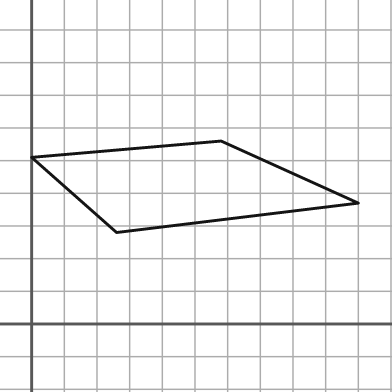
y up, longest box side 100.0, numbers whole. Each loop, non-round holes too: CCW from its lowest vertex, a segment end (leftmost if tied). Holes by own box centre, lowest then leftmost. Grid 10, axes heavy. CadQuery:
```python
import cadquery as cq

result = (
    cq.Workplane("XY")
    .moveTo(26.0, 28.0)
    .lineTo(100.0, 37.0)
    .lineTo(58.0, 56.0)
    .lineTo(0.0, 51.0)
    .close()
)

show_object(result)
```